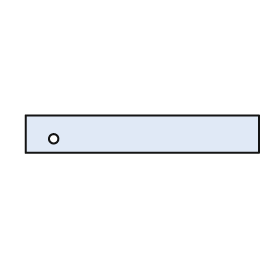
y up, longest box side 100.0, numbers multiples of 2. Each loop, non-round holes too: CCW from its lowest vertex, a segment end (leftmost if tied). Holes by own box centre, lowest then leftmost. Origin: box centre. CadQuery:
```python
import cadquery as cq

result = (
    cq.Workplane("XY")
    .moveTo(-50.0, -8.0)
    .lineTo(50.0, -8.0)
    .lineTo(50.0, 8.0)
    .lineTo(-50.0, 8.0)
    .close()
    .moveTo(-38.0, -2.0)
    .circle(2.0)
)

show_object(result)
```